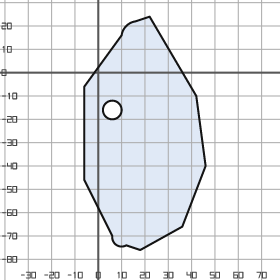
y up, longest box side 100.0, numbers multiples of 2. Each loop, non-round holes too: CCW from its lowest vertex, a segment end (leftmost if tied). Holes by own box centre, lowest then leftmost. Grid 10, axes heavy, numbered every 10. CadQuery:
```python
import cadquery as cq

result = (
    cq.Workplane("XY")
    .moveTo(18.0, -76.0)
    .lineTo(36.0, -66.0)
    .lineTo(46.0, -40.0)
    .lineTo(42.0, -10.0)
    .lineTo(22.0, 24.0)
    .lineTo(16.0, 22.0)
    .threePointArc((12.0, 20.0), (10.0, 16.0))
    .lineTo(-6.0, -6.0)
    .lineTo(-6.0, -46.0)
    .lineTo(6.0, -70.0)
    .threePointArc((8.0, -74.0), (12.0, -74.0))
    .close()
    .moveTo(6.0, -16.0)
    .circle(4.0)
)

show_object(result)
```